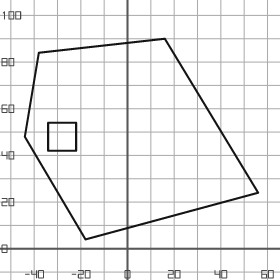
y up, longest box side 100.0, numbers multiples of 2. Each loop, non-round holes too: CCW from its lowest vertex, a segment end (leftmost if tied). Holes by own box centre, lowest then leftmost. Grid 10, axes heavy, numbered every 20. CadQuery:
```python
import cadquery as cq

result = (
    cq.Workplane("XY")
    .moveTo(-18.0, 4.0)
    .lineTo(56.0, 24.0)
    .lineTo(16.0, 90.0)
    .lineTo(-38.0, 84.0)
    .lineTo(-44.0, 48.0)
    .close()
    .moveTo(-34.0, 42.0)
    .lineTo(-22.0, 42.0)
    .lineTo(-22.0, 54.0)
    .lineTo(-34.0, 54.0)
    .close()
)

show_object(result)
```